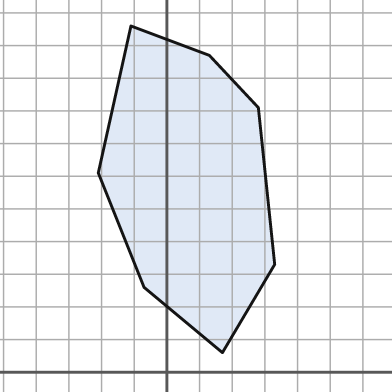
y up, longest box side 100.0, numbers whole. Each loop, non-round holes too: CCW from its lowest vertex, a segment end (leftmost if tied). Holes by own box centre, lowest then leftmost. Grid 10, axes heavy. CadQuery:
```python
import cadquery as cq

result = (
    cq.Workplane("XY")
    .moveTo(17.0, 6.0)
    .lineTo(33.0, 33.0)
    .lineTo(28.0, 81.0)
    .lineTo(13.0, 97.0)
    .lineTo(-11.0, 106.0)
    .lineTo(-21.0, 61.0)
    .lineTo(-7.0, 26.0)
    .close()
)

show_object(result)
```